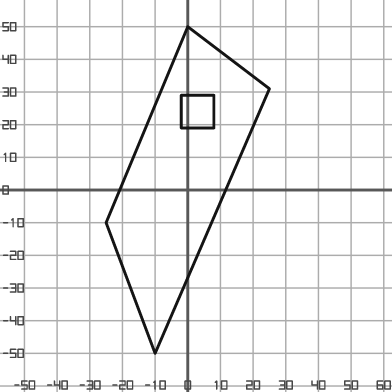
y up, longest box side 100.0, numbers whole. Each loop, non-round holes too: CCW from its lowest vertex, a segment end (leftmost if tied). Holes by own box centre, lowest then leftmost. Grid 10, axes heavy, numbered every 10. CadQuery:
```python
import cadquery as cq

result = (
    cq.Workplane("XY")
    .moveTo(-10.0, -50.0)
    .lineTo(25.0, 31.0)
    .lineTo(0.0, 50.0)
    .lineTo(-25.0, -10.0)
    .close()
    .moveTo(-2.0, 19.0)
    .lineTo(8.0, 19.0)
    .lineTo(8.0, 29.0)
    .lineTo(-2.0, 29.0)
    .close()
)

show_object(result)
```